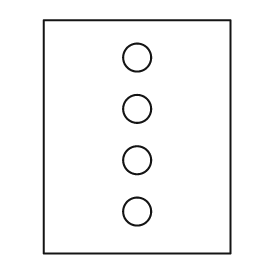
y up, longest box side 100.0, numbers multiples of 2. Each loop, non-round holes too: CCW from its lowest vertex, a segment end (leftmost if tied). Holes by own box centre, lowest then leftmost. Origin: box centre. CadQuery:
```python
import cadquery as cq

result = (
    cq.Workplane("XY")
    .moveTo(-40.0, -50.0)
    .lineTo(40.0, -50.0)
    .lineTo(40.0, 50.0)
    .lineTo(-40.0, 50.0)
    .close()
    .moveTo(0.0, -32.0)
    .circle(6.0)
    .moveTo(0.0, -10.0)
    .circle(6.0)
    .moveTo(0.0, 12.0)
    .circle(6.0)
    .moveTo(0.0, 34.0)
    .circle(6.0)
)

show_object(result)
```